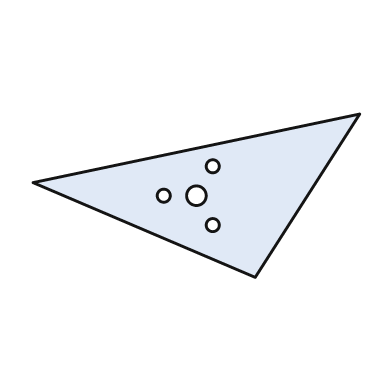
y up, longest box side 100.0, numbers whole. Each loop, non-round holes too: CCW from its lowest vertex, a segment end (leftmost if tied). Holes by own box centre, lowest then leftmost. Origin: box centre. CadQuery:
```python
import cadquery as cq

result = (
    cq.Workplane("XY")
    .moveTo(18.0, -25.0)
    .lineTo(50.0, 25.0)
    .lineTo(-50.0, 4.0)
    .close()
    .moveTo(5.0, -9.0)
    .circle(2.0)
    .moveTo(-10.0, 0.0)
    .circle(2.0)
    .moveTo(0.0, 0.0)
    .circle(3.0)
    .moveTo(5.0, 9.0)
    .circle(2.0)
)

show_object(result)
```